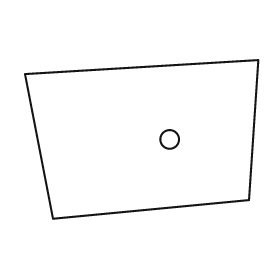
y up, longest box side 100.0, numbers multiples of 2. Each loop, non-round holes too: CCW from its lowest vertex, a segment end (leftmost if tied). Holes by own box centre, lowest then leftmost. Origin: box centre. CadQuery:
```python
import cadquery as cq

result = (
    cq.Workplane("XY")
    .moveTo(-38.0, -34.0)
    .lineTo(46.0, -26.0)
    .lineTo(50.0, 34.0)
    .lineTo(-50.0, 28.0)
    .close()
    .moveTo(12.0, 0.0)
    .circle(4.0)
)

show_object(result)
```